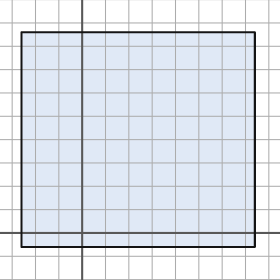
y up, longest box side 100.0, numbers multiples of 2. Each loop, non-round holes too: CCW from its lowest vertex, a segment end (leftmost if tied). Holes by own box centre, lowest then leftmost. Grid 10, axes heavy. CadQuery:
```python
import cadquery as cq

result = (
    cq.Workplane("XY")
    .moveTo(-26.0, -6.0)
    .lineTo(74.0, -6.0)
    .lineTo(74.0, 86.0)
    .lineTo(-26.0, 86.0)
    .close()
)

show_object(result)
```